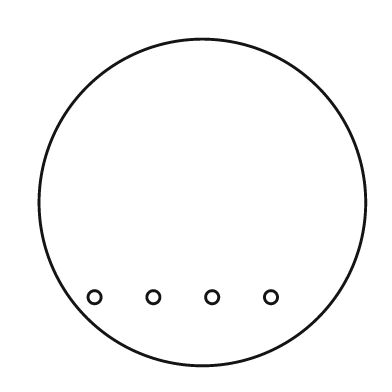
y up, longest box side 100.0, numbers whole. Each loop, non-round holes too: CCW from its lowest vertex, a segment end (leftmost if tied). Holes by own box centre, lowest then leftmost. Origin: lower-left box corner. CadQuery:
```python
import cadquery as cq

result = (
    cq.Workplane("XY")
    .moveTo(50.0, 50.0)
    .circle(50.0)
    .moveTo(17.0, 21.0)
    .circle(2.0)
    .moveTo(35.0, 21.0)
    .circle(2.0)
    .moveTo(53.0, 21.0)
    .circle(2.0)
    .moveTo(71.0, 21.0)
    .circle(2.0)
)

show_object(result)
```